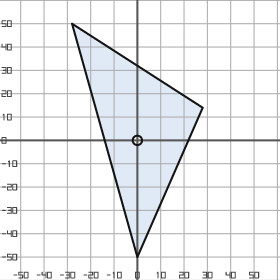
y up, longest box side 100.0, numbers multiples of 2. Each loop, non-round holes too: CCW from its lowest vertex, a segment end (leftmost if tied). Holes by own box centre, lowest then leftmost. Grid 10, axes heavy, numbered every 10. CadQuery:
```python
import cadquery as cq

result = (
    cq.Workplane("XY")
    .moveTo(0.0, -50.0)
    .lineTo(28.0, 14.0)
    .lineTo(-28.0, 50.0)
    .close()
    .moveTo(0.0, 0.0)
    .circle(2.0)
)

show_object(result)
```